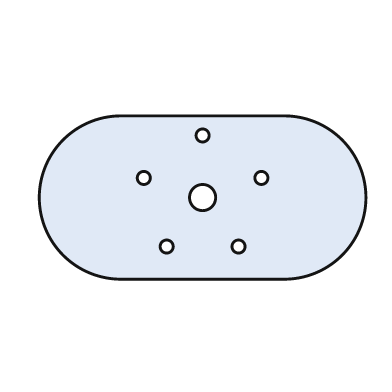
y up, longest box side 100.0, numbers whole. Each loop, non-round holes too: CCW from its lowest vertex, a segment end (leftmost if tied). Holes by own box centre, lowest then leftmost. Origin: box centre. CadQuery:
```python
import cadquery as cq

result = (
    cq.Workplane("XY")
    .moveTo(-25.0, -25.0)
    .lineTo(25.0, -25.0)
    .threePointArc((50.0, 0.0), (25.0, 25.0))
    .lineTo(-25.0, 25.0)
    .threePointArc((-50.0, 0.0), (-25.0, -25.0))
    .close()
    .moveTo(-11.0, -15.0)
    .circle(2.0)
    .moveTo(11.0, -15.0)
    .circle(2.0)
    .moveTo(0.0, 0.0)
    .circle(4.0)
    .moveTo(-18.0, 6.0)
    .circle(2.0)
    .moveTo(18.0, 6.0)
    .circle(2.0)
    .moveTo(0.0, 19.0)
    .circle(2.0)
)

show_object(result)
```